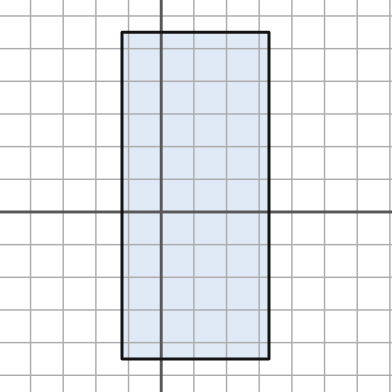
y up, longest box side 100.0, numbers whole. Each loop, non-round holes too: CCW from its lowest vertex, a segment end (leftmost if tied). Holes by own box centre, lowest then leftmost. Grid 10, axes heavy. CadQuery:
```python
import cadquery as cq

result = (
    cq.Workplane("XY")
    .moveTo(-12.0, -45.0)
    .lineTo(33.0, -45.0)
    .lineTo(33.0, 55.0)
    .lineTo(-12.0, 55.0)
    .close()
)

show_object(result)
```